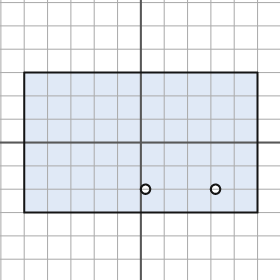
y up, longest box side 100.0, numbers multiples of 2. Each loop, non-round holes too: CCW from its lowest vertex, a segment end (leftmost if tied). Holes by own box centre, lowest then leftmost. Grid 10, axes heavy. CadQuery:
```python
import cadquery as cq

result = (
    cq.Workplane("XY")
    .moveTo(-50.0, -30.0)
    .lineTo(50.0, -30.0)
    .lineTo(50.0, 30.0)
    .lineTo(-50.0, 30.0)
    .close()
    .moveTo(2.0, -20.0)
    .circle(2.0)
    .moveTo(32.0, -20.0)
    .circle(2.0)
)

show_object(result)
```